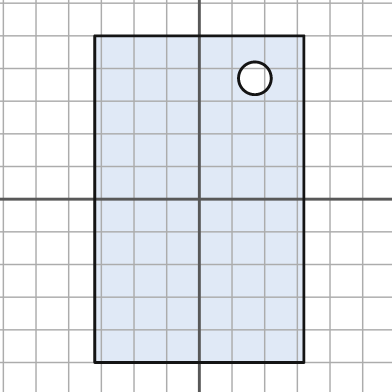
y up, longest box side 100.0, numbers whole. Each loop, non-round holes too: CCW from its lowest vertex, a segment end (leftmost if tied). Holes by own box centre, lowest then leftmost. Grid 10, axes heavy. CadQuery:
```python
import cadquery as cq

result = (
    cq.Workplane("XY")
    .moveTo(-32.0, -50.0)
    .lineTo(32.0, -50.0)
    .lineTo(32.0, 50.0)
    .lineTo(-32.0, 50.0)
    .close()
    .moveTo(17.0, 37.0)
    .circle(5.0)
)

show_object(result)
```